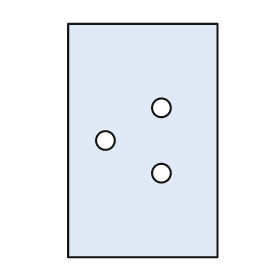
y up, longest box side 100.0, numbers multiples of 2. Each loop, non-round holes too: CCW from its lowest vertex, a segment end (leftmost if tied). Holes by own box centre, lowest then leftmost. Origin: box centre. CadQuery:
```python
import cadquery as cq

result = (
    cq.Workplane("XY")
    .moveTo(-32.0, -50.0)
    .lineTo(32.0, -50.0)
    .lineTo(32.0, 50.0)
    .lineTo(-32.0, 50.0)
    .close()
    .moveTo(8.0, -14.0)
    .circle(4.0)
    .moveTo(-16.0, 0.0)
    .circle(4.0)
    .moveTo(8.0, 14.0)
    .circle(4.0)
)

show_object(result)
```